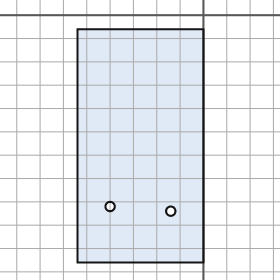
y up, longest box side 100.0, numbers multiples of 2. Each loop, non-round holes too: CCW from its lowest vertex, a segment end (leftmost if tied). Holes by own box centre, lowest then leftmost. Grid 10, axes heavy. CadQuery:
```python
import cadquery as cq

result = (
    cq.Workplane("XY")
    .moveTo(-54.0, -106.0)
    .lineTo(0.0, -106.0)
    .lineTo(0.0, -6.0)
    .lineTo(-54.0, -6.0)
    .close()
    .moveTo(-14.0, -84.0)
    .circle(2.0)
    .moveTo(-40.0, -82.0)
    .circle(2.0)
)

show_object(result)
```